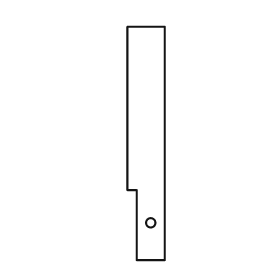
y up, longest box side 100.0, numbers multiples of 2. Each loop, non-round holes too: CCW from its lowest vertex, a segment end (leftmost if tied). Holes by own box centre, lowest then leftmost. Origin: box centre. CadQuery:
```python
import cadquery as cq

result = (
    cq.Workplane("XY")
    .moveTo(-4.0, -50.0)
    .lineTo(8.0, -50.0)
    .lineTo(8.0, 50.0)
    .lineTo(-8.0, 50.0)
    .lineTo(-8.0, -20.0)
    .lineTo(-4.0, -20.0)
    .close()
    .moveTo(2.0, -34.0)
    .circle(2.0)
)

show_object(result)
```